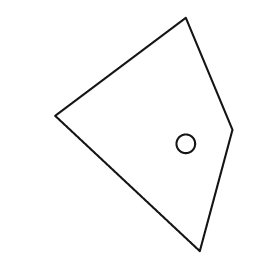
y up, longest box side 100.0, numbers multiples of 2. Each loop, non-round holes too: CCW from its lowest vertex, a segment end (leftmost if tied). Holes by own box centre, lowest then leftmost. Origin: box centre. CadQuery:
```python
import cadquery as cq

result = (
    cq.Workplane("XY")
    .moveTo(24.0, -50.0)
    .lineTo(38.0, 2.0)
    .lineTo(18.0, 50.0)
    .lineTo(-38.0, 8.0)
    .close()
    .moveTo(18.0, -4.0)
    .circle(4.0)
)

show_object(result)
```